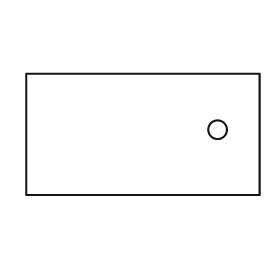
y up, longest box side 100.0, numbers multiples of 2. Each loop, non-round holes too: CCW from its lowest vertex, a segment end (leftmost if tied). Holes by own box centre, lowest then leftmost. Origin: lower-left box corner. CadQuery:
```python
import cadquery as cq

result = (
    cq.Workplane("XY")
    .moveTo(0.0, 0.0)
    .lineTo(100.0, 0.0)
    .lineTo(100.0, 52.0)
    .lineTo(0.0, 52.0)
    .close()
    .moveTo(82.0, 28.0)
    .circle(4.0)
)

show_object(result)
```